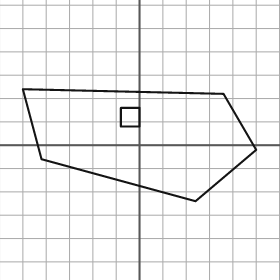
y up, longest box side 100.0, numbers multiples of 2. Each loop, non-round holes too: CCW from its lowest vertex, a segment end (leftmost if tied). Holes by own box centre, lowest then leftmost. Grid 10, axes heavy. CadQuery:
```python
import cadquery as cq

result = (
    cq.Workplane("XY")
    .moveTo(24.0, -24.0)
    .lineTo(50.0, -2.0)
    .lineTo(36.0, 22.0)
    .lineTo(-50.0, 24.0)
    .lineTo(-42.0, -6.0)
    .close()
    .moveTo(-8.0, 8.0)
    .lineTo(0.0, 8.0)
    .lineTo(0.0, 16.0)
    .lineTo(-8.0, 16.0)
    .close()
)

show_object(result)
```